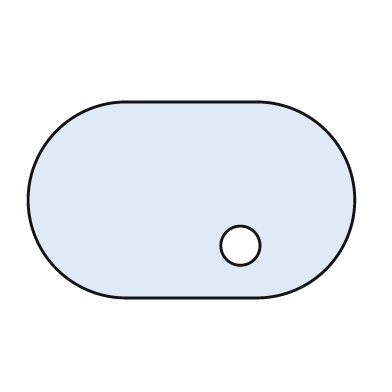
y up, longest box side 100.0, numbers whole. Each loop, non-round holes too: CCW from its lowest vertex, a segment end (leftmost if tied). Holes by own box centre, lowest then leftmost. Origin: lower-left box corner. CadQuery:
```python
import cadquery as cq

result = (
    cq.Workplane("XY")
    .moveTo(30.0, 0.0)
    .lineTo(70.0, 0.0)
    .threePointArc((100.0, 30.0), (70.0, 60.0))
    .lineTo(30.0, 60.0)
    .threePointArc((0.0, 30.0), (30.0, 0.0))
    .close()
    .moveTo(65.0, 16.0)
    .circle(6.0)
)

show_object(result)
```